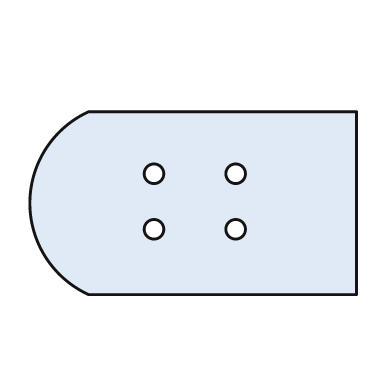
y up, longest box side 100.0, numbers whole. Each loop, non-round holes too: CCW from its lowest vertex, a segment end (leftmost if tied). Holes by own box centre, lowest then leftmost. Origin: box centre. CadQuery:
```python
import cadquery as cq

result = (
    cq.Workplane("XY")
    .moveTo(-32.0, -28.0)
    .lineTo(50.0, -28.0)
    .lineTo(50.0, 28.0)
    .lineTo(-32.0, 28.0)
    .threePointArc((-50.0, 0.0), (-32.0, -28.0))
    .close()
    .moveTo(-12.0, -8.0)
    .circle(3.0)
    .moveTo(13.0, -8.0)
    .circle(3.0)
    .moveTo(-12.0, 9.0)
    .circle(3.0)
    .moveTo(13.0, 9.0)
    .circle(3.0)
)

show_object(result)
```